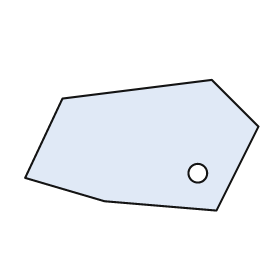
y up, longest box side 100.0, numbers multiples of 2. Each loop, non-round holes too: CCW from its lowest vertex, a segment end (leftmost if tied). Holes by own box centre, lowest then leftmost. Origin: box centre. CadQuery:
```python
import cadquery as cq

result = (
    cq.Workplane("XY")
    .moveTo(32.0, -28.0)
    .lineTo(50.0, 8.0)
    .lineTo(30.0, 28.0)
    .lineTo(-34.0, 20.0)
    .lineTo(-50.0, -14.0)
    .lineTo(-16.0, -24.0)
    .close()
    .moveTo(24.0, -12.0)
    .circle(4.0)
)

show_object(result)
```